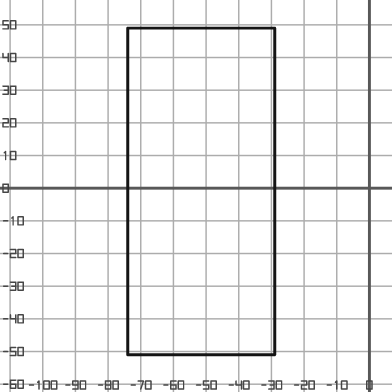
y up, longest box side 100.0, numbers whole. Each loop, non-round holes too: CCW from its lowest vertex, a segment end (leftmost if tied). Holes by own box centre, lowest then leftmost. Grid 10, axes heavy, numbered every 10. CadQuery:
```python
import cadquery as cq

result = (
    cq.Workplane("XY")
    .moveTo(-74.0, -51.0)
    .lineTo(-29.0, -51.0)
    .lineTo(-29.0, 49.0)
    .lineTo(-74.0, 49.0)
    .close()
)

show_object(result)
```